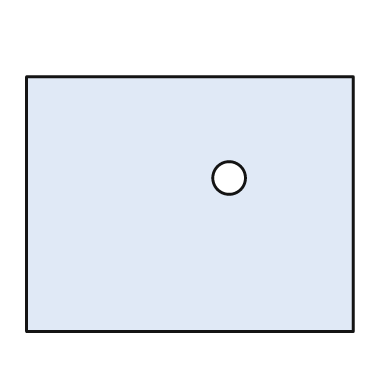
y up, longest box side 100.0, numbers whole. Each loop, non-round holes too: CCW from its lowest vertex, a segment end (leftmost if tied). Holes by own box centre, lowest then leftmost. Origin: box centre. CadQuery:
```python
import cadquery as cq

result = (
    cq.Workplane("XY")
    .moveTo(-50.0, -39.0)
    .lineTo(50.0, -39.0)
    .lineTo(50.0, 39.0)
    .lineTo(-50.0, 39.0)
    .close()
    .moveTo(12.0, 8.0)
    .circle(5.0)
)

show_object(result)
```